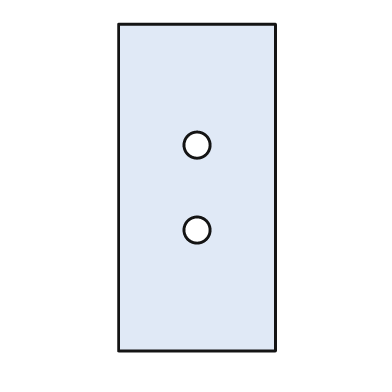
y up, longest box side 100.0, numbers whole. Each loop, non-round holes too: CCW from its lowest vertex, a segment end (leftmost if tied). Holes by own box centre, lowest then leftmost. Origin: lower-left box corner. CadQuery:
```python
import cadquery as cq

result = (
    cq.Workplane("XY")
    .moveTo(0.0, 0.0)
    .lineTo(48.0, 0.0)
    .lineTo(48.0, 100.0)
    .lineTo(0.0, 100.0)
    .close()
    .moveTo(24.0, 37.0)
    .circle(4.0)
    .moveTo(24.0, 63.0)
    .circle(4.0)
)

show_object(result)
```